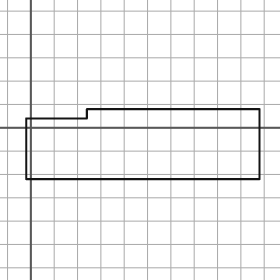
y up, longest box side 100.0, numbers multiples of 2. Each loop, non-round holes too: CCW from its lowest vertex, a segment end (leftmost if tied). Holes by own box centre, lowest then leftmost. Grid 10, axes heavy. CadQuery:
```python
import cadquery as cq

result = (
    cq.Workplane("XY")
    .moveTo(-2.0, -22.0)
    .lineTo(98.0, -22.0)
    .lineTo(98.0, 8.0)
    .lineTo(24.0, 8.0)
    .lineTo(24.0, 4.0)
    .lineTo(-2.0, 4.0)
    .close()
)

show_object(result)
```